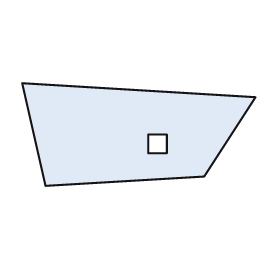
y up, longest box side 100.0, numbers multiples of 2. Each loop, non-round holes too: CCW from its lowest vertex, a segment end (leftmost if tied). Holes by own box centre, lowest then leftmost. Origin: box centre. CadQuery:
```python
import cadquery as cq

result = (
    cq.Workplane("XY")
    .moveTo(-40.0, -22.0)
    .lineTo(28.0, -18.0)
    .lineTo(50.0, 16.0)
    .lineTo(-50.0, 22.0)
    .close()
    .moveTo(4.0, -8.0)
    .lineTo(12.0, -8.0)
    .lineTo(12.0, 0.0)
    .lineTo(4.0, 0.0)
    .close()
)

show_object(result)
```